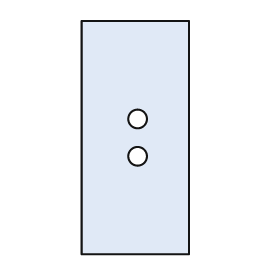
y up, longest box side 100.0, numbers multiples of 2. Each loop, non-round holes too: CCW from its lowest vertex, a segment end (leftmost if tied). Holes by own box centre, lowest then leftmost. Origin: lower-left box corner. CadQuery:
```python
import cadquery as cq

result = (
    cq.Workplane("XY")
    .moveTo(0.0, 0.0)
    .lineTo(46.0, 0.0)
    .lineTo(46.0, 100.0)
    .lineTo(0.0, 100.0)
    .close()
    .moveTo(24.0, 42.0)
    .circle(4.0)
    .moveTo(24.0, 58.0)
    .circle(4.0)
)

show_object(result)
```